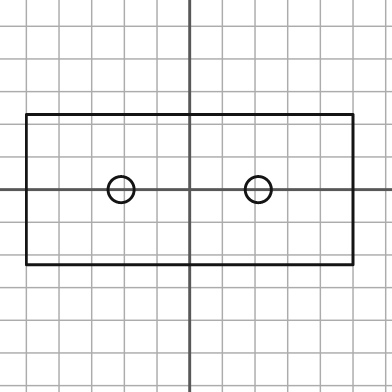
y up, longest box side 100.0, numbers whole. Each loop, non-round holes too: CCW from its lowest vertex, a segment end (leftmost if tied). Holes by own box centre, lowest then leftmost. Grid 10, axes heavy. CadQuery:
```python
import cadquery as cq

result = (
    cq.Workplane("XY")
    .moveTo(-50.0, -23.0)
    .lineTo(50.0, -23.0)
    .lineTo(50.0, 23.0)
    .lineTo(-50.0, 23.0)
    .close()
    .moveTo(-21.0, 0.0)
    .circle(4.0)
    .moveTo(21.0, 0.0)
    .circle(4.0)
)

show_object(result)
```